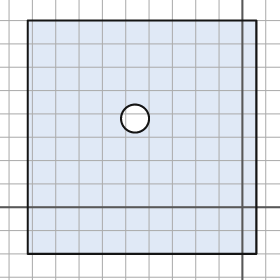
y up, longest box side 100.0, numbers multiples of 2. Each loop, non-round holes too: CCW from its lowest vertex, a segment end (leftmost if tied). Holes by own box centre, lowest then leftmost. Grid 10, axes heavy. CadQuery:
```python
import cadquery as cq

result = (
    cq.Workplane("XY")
    .moveTo(-92.0, -20.0)
    .lineTo(6.0, -20.0)
    .lineTo(6.0, 80.0)
    .lineTo(-92.0, 80.0)
    .close()
    .moveTo(-46.0, 38.0)
    .circle(6.0)
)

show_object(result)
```